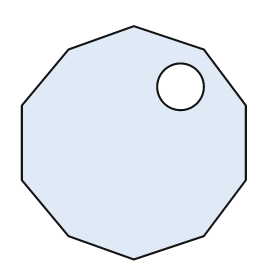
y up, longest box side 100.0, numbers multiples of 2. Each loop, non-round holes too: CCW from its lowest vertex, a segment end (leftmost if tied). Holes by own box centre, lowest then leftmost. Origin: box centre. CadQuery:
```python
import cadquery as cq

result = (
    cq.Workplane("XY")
    .moveTo(0.0, -50.0)
    .lineTo(30.0, -40.0)
    .lineTo(48.0, -16.0)
    .lineTo(48.0, 16.0)
    .lineTo(30.0, 40.0)
    .lineTo(0.0, 50.0)
    .lineTo(-28.0, 40.0)
    .lineTo(-48.0, 16.0)
    .lineTo(-48.0, -16.0)
    .lineTo(-28.0, -40.0)
    .close()
    .moveTo(20.0, 24.0)
    .circle(10.0)
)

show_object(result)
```